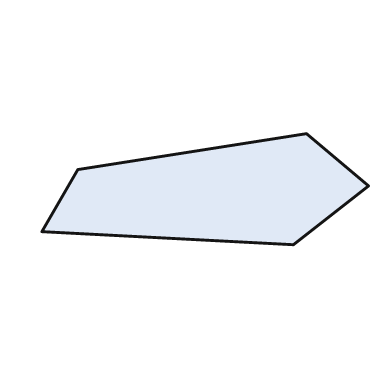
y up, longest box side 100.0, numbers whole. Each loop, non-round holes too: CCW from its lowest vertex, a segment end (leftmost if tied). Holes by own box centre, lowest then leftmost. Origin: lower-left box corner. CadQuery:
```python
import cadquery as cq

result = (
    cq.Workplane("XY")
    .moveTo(77.0, 0.0)
    .lineTo(100.0, 18.0)
    .lineTo(81.0, 34.0)
    .lineTo(11.0, 23.0)
    .lineTo(0.0, 4.0)
    .close()
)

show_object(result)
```